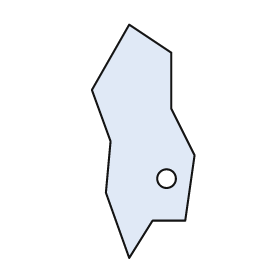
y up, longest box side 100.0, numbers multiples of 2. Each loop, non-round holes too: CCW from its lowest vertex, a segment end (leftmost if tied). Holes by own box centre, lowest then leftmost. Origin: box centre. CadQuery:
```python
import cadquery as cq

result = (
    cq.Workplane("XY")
    .moveTo(-6.0, -50.0)
    .lineTo(4.0, -34.0)
    .lineTo(18.0, -34.0)
    .lineTo(22.0, -6.0)
    .lineTo(12.0, 14.0)
    .lineTo(12.0, 38.0)
    .lineTo(-6.0, 50.0)
    .lineTo(-22.0, 22.0)
    .lineTo(-14.0, 0.0)
    .lineTo(-16.0, -22.0)
    .close()
    .moveTo(10.0, -16.0)
    .circle(4.0)
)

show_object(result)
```